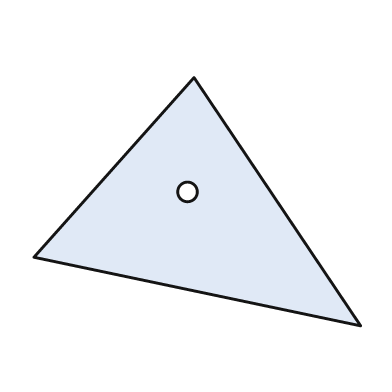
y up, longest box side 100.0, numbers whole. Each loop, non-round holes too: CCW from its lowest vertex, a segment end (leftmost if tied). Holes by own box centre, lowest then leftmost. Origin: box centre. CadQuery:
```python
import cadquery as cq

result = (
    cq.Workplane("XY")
    .moveTo(50.0, -38.0)
    .lineTo(-1.0, 38.0)
    .lineTo(-50.0, -17.0)
    .close()
    .moveTo(-3.0, 3.0)
    .circle(3.0)
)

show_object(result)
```